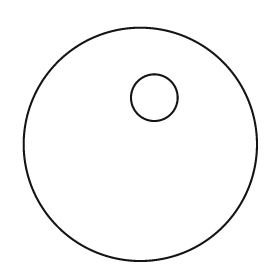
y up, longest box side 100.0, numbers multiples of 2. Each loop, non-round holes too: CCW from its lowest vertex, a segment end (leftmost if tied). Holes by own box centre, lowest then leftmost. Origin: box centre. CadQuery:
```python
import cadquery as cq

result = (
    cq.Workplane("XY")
    .moveTo(0.0, 0.0)
    .circle(50.0)
    .moveTo(6.0, 20.0)
    .circle(10.0)
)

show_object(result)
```